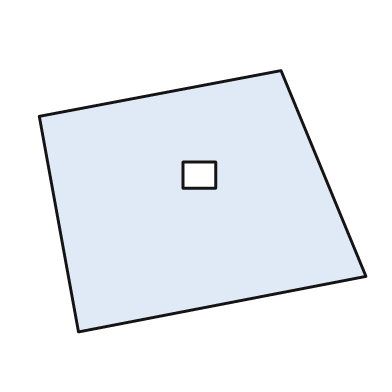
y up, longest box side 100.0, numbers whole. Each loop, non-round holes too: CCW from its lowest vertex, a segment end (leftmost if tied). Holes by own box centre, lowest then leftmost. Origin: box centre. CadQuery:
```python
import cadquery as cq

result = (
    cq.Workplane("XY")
    .moveTo(-38.0, -40.0)
    .lineTo(50.0, -23.0)
    .lineTo(24.0, 40.0)
    .lineTo(-50.0, 26.0)
    .close()
    .moveTo(-6.0, 4.0)
    .lineTo(4.0, 4.0)
    .lineTo(4.0, 12.0)
    .lineTo(-6.0, 12.0)
    .close()
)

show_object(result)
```